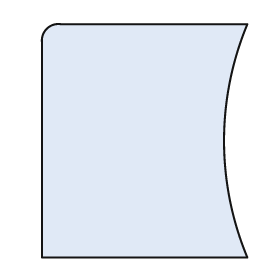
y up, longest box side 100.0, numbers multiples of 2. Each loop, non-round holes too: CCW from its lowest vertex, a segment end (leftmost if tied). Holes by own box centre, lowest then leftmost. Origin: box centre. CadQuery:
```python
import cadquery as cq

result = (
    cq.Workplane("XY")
    .moveTo(-44.0, -50.0)
    .lineTo(44.0, -50.0)
    .threePointArc((34.0, 0.0), (44.0, 50.0))
    .lineTo(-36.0, 50.0)
    .threePointArc((-42.0, 48.0), (-44.0, 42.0))
    .close()
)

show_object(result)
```